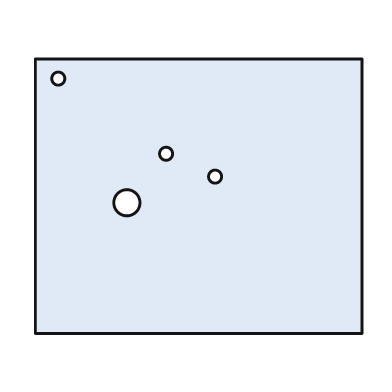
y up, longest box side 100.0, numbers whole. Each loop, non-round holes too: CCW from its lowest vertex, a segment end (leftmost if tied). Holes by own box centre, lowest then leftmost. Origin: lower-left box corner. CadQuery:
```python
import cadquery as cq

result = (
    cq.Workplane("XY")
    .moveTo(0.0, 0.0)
    .lineTo(100.0, 0.0)
    .lineTo(100.0, 84.0)
    .lineTo(0.0, 84.0)
    .close()
    .moveTo(28.0, 40.0)
    .circle(4.0)
    .moveTo(55.0, 48.0)
    .circle(2.0)
    .moveTo(40.0, 55.0)
    .circle(2.0)
    .moveTo(7.0, 78.0)
    .circle(2.0)
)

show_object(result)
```